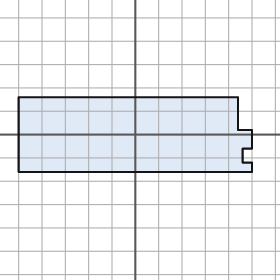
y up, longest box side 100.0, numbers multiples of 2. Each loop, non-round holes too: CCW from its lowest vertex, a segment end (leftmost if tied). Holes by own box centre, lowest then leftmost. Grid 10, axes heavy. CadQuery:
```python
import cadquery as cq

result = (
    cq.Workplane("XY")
    .moveTo(-50.0, -16.0)
    .lineTo(50.0, -16.0)
    .lineTo(50.0, -12.0)
    .lineTo(46.0, -12.0)
    .lineTo(46.0, -6.0)
    .lineTo(50.0, -6.0)
    .lineTo(50.0, 2.0)
    .lineTo(44.0, 2.0)
    .lineTo(44.0, 16.0)
    .lineTo(-50.0, 16.0)
    .close()
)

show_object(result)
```